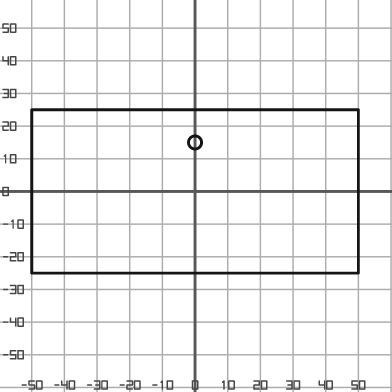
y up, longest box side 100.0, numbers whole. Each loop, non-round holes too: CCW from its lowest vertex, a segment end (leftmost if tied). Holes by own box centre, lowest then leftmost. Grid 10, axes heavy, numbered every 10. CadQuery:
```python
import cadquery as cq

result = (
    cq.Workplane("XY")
    .moveTo(-50.0, -25.0)
    .lineTo(50.0, -25.0)
    .lineTo(50.0, 25.0)
    .lineTo(-50.0, 25.0)
    .close()
    .moveTo(0.0, 15.0)
    .circle(2.0)
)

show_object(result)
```